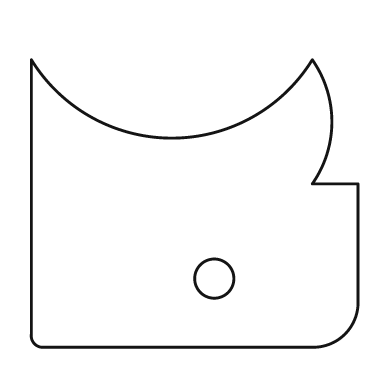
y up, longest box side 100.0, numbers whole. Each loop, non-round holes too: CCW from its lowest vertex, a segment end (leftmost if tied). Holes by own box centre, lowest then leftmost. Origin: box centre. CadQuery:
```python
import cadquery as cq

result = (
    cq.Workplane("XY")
    .moveTo(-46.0, -44.0)
    .lineTo(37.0, -44.0)
    .threePointArc((46.0, -40.0), (50.0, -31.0))
    .lineTo(50.0, 6.0)
    .lineTo(36.0, 6.0)
    .threePointArc((42.0, 25.0), (36.0, 44.0))
    .threePointArc((-7.0, 20.0), (-50.0, 44.0))
    .lineTo(-50.0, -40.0)
    .threePointArc((-49.0, -43.0), (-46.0, -44.0))
    .close()
    .moveTo(6.0, -23.0)
    .circle(6.0)
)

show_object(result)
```